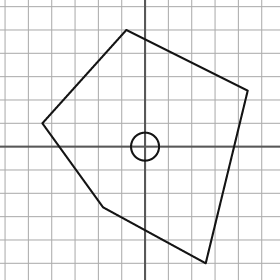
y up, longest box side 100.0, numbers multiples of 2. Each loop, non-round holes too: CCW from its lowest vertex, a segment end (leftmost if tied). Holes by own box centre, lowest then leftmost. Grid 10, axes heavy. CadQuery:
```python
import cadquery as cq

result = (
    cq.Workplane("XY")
    .moveTo(26.0, -50.0)
    .lineTo(44.0, 24.0)
    .lineTo(-8.0, 50.0)
    .lineTo(-44.0, 10.0)
    .lineTo(-18.0, -26.0)
    .close()
    .moveTo(0.0, 0.0)
    .circle(6.0)
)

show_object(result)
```